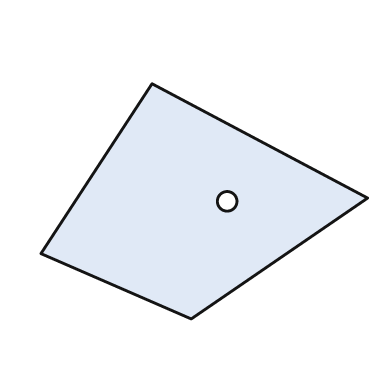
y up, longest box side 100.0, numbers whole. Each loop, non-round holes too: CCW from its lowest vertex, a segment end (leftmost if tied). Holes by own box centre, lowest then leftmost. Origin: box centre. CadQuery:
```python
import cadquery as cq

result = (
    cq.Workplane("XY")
    .moveTo(-4.0, -36.0)
    .lineTo(50.0, 1.0)
    .lineTo(-16.0, 36.0)
    .lineTo(-50.0, -16.0)
    .close()
    .moveTo(7.0, 0.0)
    .circle(3.0)
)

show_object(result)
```